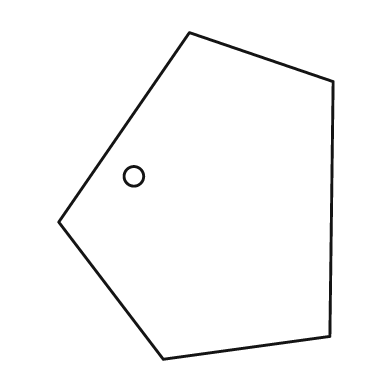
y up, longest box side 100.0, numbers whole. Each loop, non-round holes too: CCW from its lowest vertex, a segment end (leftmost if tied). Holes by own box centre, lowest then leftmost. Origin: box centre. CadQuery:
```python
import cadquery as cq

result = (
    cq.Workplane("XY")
    .moveTo(-10.0, -50.0)
    .lineTo(41.0, -43.0)
    .lineTo(42.0, 35.0)
    .lineTo(-2.0, 50.0)
    .lineTo(-42.0, -8.0)
    .close()
    .moveTo(-19.0, 6.0)
    .circle(3.0)
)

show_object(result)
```